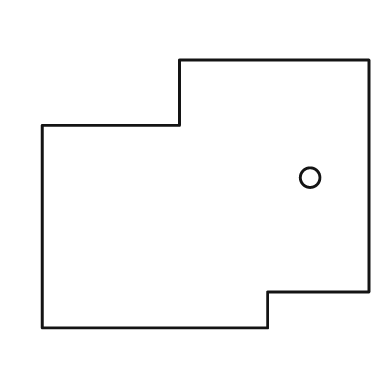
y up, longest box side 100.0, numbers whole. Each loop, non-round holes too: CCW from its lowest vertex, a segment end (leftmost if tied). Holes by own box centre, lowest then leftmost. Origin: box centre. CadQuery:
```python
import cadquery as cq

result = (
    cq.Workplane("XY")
    .moveTo(-50.0, -41.0)
    .lineTo(19.0, -41.0)
    .lineTo(19.0, -30.0)
    .lineTo(50.0, -30.0)
    .lineTo(50.0, 41.0)
    .lineTo(-8.0, 41.0)
    .lineTo(-8.0, 21.0)
    .lineTo(-50.0, 21.0)
    .close()
    .moveTo(32.0, 5.0)
    .circle(3.0)
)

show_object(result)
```